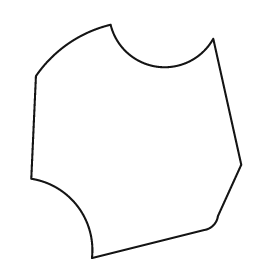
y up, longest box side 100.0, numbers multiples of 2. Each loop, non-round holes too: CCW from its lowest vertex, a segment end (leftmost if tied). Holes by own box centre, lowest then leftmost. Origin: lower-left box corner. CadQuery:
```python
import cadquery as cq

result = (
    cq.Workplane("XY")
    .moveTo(26.0, 0.0)
    .lineTo(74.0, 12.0)
    .threePointArc((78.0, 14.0), (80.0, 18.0))
    .lineTo(90.0, 40.0)
    .lineTo(78.0, 94.0)
    .threePointArc((54.0, 82.0), (34.0, 100.0))
    .threePointArc((16.0, 92.0), (2.0, 78.0))
    .lineTo(0.0, 34.0)
    .threePointArc((20.0, 22.0), (26.0, 0.0))
    .close()
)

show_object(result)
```